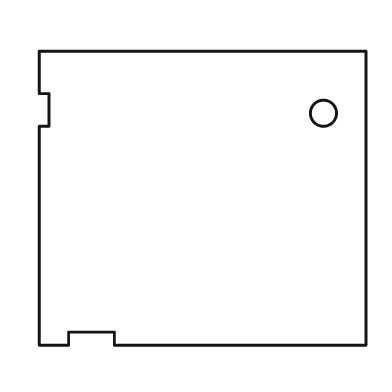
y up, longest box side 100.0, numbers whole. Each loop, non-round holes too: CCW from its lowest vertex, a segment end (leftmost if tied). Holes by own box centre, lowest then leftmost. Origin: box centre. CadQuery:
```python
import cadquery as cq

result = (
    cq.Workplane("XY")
    .moveTo(-50.0, -45.0)
    .lineTo(-41.0, -45.0)
    .lineTo(-41.0, -41.0)
    .lineTo(-27.0, -41.0)
    .lineTo(-27.0, -45.0)
    .lineTo(50.0, -45.0)
    .lineTo(50.0, 45.0)
    .lineTo(-50.0, 45.0)
    .lineTo(-50.0, 32.0)
    .lineTo(-47.0, 32.0)
    .lineTo(-47.0, 22.0)
    .lineTo(-50.0, 22.0)
    .close()
    .moveTo(37.0, 26.0)
    .circle(4.0)
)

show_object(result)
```